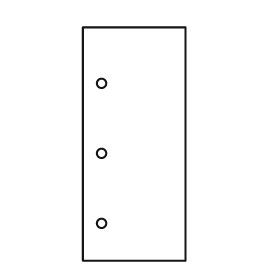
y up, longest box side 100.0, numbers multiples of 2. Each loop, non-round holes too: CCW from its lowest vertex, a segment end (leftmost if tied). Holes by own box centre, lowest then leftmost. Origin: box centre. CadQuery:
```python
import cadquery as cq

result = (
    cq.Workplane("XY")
    .moveTo(-22.0, -50.0)
    .lineTo(22.0, -50.0)
    .lineTo(22.0, 50.0)
    .lineTo(-22.0, 50.0)
    .close()
    .moveTo(-14.0, -34.0)
    .circle(2.0)
    .moveTo(-14.0, -4.0)
    .circle(2.0)
    .moveTo(-14.0, 26.0)
    .circle(2.0)
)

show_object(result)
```